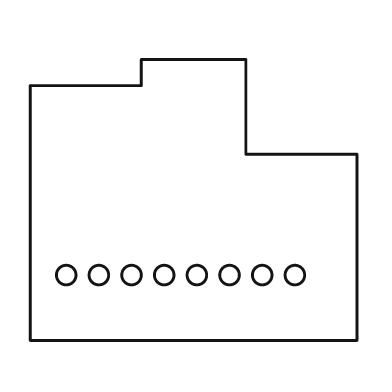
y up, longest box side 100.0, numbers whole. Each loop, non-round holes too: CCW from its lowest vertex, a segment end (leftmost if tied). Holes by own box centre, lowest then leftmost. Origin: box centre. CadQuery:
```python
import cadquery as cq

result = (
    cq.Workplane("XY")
    .moveTo(-50.0, -43.0)
    .lineTo(50.0, -43.0)
    .lineTo(50.0, 14.0)
    .lineTo(16.0, 14.0)
    .lineTo(16.0, 43.0)
    .lineTo(-16.0, 43.0)
    .lineTo(-16.0, 35.0)
    .lineTo(-50.0, 35.0)
    .close()
    .moveTo(-39.0, -23.0)
    .circle(3.0)
    .moveTo(-29.0, -23.0)
    .circle(3.0)
    .moveTo(-19.0, -23.0)
    .circle(3.0)
    .moveTo(-9.0, -23.0)
    .circle(3.0)
    .moveTo(1.0, -23.0)
    .circle(3.0)
    .moveTo(11.0, -23.0)
    .circle(3.0)
    .moveTo(21.0, -23.0)
    .circle(3.0)
    .moveTo(31.0, -23.0)
    .circle(3.0)
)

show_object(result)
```